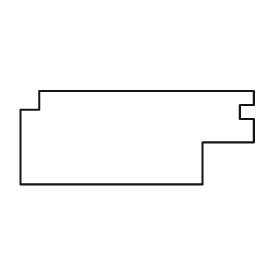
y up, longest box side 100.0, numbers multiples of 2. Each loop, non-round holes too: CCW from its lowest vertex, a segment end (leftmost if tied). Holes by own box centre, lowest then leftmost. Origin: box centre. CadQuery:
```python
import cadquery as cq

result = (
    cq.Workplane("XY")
    .moveTo(-50.0, -20.0)
    .lineTo(28.0, -20.0)
    .lineTo(28.0, -2.0)
    .lineTo(50.0, -2.0)
    .lineTo(50.0, 8.0)
    .lineTo(44.0, 8.0)
    .lineTo(44.0, 14.0)
    .lineTo(50.0, 14.0)
    .lineTo(50.0, 20.0)
    .lineTo(-42.0, 20.0)
    .lineTo(-42.0, 12.0)
    .lineTo(-50.0, 12.0)
    .close()
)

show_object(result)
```